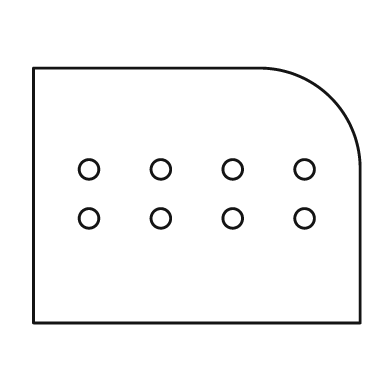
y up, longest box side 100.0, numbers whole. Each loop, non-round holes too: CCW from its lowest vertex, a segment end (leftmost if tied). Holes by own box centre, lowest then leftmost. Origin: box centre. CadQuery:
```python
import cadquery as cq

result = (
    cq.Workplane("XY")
    .moveTo(-50.0, -39.0)
    .lineTo(50.0, -39.0)
    .lineTo(50.0, 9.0)
    .threePointArc((41.0, 30.0), (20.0, 39.0))
    .lineTo(-50.0, 39.0)
    .close()
    .moveTo(-33.0, -7.0)
    .circle(3.0)
    .moveTo(-11.0, -7.0)
    .circle(3.0)
    .moveTo(11.0, -7.0)
    .circle(3.0)
    .moveTo(33.0, -7.0)
    .circle(3.0)
    .moveTo(-33.0, 8.0)
    .circle(3.0)
    .moveTo(-11.0, 8.0)
    .circle(3.0)
    .moveTo(11.0, 8.0)
    .circle(3.0)
    .moveTo(33.0, 8.0)
    .circle(3.0)
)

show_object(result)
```